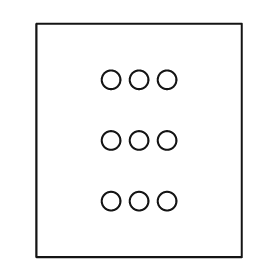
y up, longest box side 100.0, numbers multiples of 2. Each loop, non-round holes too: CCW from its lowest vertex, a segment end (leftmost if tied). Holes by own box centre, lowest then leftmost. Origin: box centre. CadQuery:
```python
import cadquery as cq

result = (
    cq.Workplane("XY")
    .moveTo(-44.0, -50.0)
    .lineTo(44.0, -50.0)
    .lineTo(44.0, 50.0)
    .lineTo(-44.0, 50.0)
    .close()
    .moveTo(-12.0, -26.0)
    .circle(4.0)
    .moveTo(0.0, -26.0)
    .circle(4.0)
    .moveTo(12.0, -26.0)
    .circle(4.0)
    .moveTo(-12.0, 0.0)
    .circle(4.0)
    .moveTo(0.0, 0.0)
    .circle(4.0)
    .moveTo(12.0, 0.0)
    .circle(4.0)
    .moveTo(-12.0, 26.0)
    .circle(4.0)
    .moveTo(0.0, 26.0)
    .circle(4.0)
    .moveTo(12.0, 26.0)
    .circle(4.0)
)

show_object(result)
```